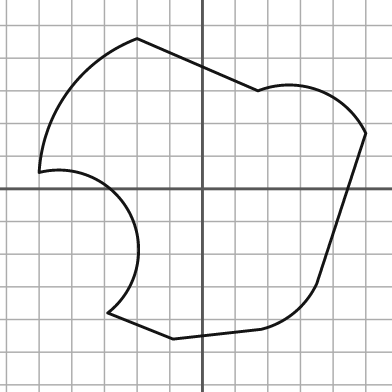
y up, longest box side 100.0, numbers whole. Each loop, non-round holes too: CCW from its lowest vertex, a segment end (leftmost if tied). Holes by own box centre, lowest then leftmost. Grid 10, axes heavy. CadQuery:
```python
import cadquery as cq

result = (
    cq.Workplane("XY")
    .moveTo(-9.0, -46.0)
    .lineTo(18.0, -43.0)
    .threePointArc((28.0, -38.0), (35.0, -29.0))
    .lineTo(50.0, 17.0)
    .threePointArc((36.0, 30.0), (17.0, 30.0))
    .lineTo(-20.0, 46.0)
    .threePointArc((-41.0, 30.0), (-50.0, 5.0))
    .threePointArc((-22.0, -8.0), (-29.0, -38.0))
    .close()
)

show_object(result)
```